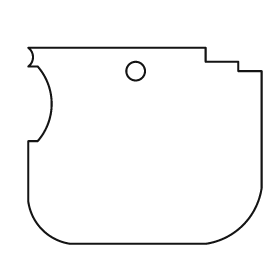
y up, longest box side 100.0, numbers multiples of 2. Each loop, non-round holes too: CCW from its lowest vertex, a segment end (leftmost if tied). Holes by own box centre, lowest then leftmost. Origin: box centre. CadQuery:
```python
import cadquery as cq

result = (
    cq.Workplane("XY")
    .moveTo(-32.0, -42.0)
    .lineTo(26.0, -42.0)
    .threePointArc((42.0, -34.0), (50.0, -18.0))
    .lineTo(50.0, 32.0)
    .lineTo(40.0, 32.0)
    .lineTo(40.0, 36.0)
    .lineTo(26.0, 36.0)
    .lineTo(26.0, 42.0)
    .lineTo(-50.0, 42.0)
    .threePointArc((-48.0, 38.0), (-50.0, 34.0))
    .lineTo(-46.0, 34.0)
    .threePointArc((-40.0, 18.0), (-46.0, 2.0))
    .lineTo(-50.0, 2.0)
    .lineTo(-50.0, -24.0)
    .threePointArc((-44.0, -36.0), (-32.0, -42.0))
    .close()
    .moveTo(-4.0, 32.0)
    .circle(4.0)
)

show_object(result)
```